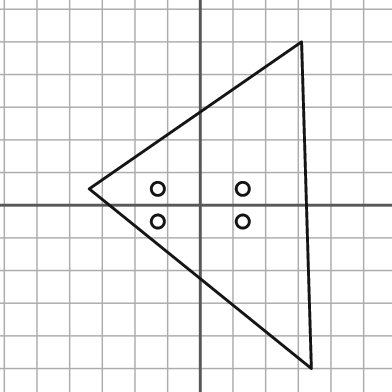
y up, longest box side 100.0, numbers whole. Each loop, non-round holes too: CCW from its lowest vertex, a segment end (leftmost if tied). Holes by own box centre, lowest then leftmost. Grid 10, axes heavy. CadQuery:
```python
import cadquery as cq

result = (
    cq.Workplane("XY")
    .moveTo(34.0, -50.0)
    .lineTo(31.0, 50.0)
    .lineTo(-34.0, 5.0)
    .close()
    .moveTo(-13.0, -5.0)
    .circle(2.0)
    .moveTo(13.0, -5.0)
    .circle(2.0)
    .moveTo(-13.0, 5.0)
    .circle(2.0)
    .moveTo(13.0, 5.0)
    .circle(2.0)
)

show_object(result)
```